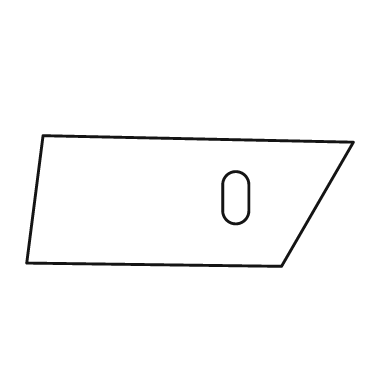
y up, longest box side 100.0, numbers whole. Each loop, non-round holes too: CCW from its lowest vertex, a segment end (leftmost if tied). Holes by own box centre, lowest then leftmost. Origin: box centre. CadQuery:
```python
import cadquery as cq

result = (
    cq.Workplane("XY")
    .moveTo(28.0, -20.0)
    .lineTo(50.0, 18.0)
    .lineTo(-45.0, 20.0)
    .lineTo(-50.0, -19.0)
    .close()
    .moveTo(10.0, -3.0)
    .threePointArc((14.0, -7.0), (18.0, -3.0))
    .lineTo(18.0, 5.0)
    .threePointArc((14.0, 9.0), (10.0, 5.0))
    .close()
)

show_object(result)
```